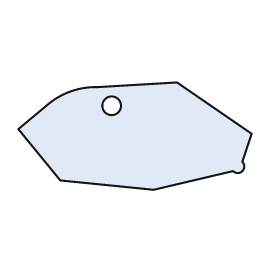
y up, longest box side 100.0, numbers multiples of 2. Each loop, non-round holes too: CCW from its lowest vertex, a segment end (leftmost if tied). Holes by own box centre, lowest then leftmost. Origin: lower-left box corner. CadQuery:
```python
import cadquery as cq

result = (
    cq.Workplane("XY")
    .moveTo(58.0, 0.0)
    .lineTo(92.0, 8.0)
    .threePointArc((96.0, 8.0), (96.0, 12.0))
    .lineTo(100.0, 24.0)
    .lineTo(68.0, 46.0)
    .lineTo(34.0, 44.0)
    .threePointArc((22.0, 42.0), (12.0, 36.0))
    .lineTo(0.0, 26.0)
    .lineTo(18.0, 4.0)
    .close()
    .moveTo(40.0, 36.0)
    .circle(4.0)
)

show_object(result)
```